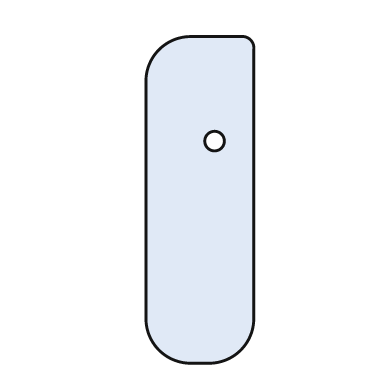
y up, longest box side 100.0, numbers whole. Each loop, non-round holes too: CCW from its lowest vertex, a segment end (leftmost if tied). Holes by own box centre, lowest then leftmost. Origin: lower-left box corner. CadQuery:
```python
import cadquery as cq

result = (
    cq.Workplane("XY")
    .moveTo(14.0, 0.0)
    .lineTo(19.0, 0.0)
    .threePointArc((29.0, 4.0), (33.0, 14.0))
    .lineTo(33.0, 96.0)
    .threePointArc((32.0, 99.0), (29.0, 100.0))
    .lineTo(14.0, 100.0)
    .threePointArc((4.0, 96.0), (0.0, 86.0))
    .lineTo(0.0, 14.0)
    .threePointArc((4.0, 4.0), (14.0, 0.0))
    .close()
    .moveTo(21.0, 68.0)
    .circle(3.0)
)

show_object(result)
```